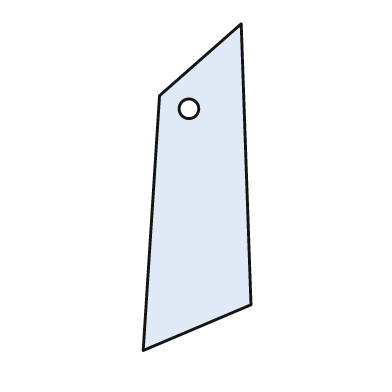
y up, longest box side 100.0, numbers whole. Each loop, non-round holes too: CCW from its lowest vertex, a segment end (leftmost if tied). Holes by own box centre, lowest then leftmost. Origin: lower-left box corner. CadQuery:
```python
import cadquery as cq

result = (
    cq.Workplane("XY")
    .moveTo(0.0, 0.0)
    .lineTo(33.0, 14.0)
    .lineTo(30.0, 100.0)
    .lineTo(5.0, 78.0)
    .close()
    .moveTo(14.0, 74.0)
    .circle(3.0)
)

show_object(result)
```